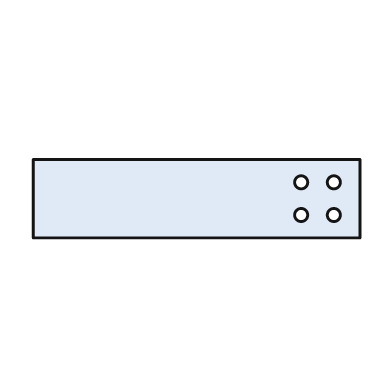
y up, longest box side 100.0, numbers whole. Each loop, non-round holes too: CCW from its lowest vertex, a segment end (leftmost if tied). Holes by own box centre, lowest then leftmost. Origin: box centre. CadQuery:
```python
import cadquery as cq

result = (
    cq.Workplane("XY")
    .moveTo(-50.0, -12.0)
    .lineTo(50.0, -12.0)
    .lineTo(50.0, 12.0)
    .lineTo(-50.0, 12.0)
    .close()
    .moveTo(32.0, -5.0)
    .circle(2.0)
    .moveTo(42.0, -5.0)
    .circle(2.0)
    .moveTo(32.0, 5.0)
    .circle(2.0)
    .moveTo(42.0, 5.0)
    .circle(2.0)
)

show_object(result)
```